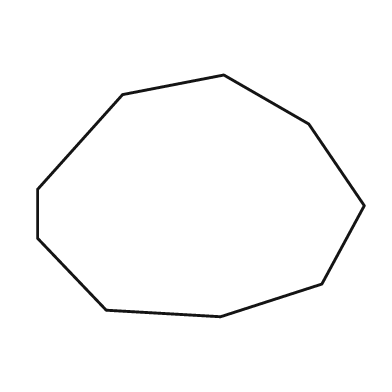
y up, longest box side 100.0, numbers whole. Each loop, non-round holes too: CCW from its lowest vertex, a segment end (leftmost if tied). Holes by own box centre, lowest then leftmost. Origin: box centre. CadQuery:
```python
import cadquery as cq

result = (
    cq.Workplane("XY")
    .moveTo(6.0, -37.0)
    .lineTo(37.0, -27.0)
    .lineTo(50.0, -3.0)
    .lineTo(33.0, 22.0)
    .lineTo(7.0, 37.0)
    .lineTo(-24.0, 31.0)
    .lineTo(-50.0, 2.0)
    .lineTo(-50.0, -13.0)
    .lineTo(-29.0, -35.0)
    .close()
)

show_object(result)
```